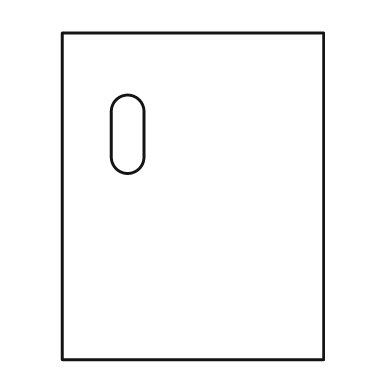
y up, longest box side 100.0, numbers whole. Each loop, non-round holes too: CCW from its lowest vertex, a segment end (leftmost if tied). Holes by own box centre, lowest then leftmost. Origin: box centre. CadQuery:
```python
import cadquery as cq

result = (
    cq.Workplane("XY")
    .moveTo(-40.0, -50.0)
    .lineTo(40.0, -50.0)
    .lineTo(40.0, 50.0)
    .lineTo(-40.0, 50.0)
    .close()
    .moveTo(-25.0, 12.0)
    .threePointArc((-20.0, 7.0), (-15.0, 12.0))
    .lineTo(-15.0, 26.0)
    .threePointArc((-20.0, 31.0), (-25.0, 26.0))
    .close()
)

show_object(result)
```